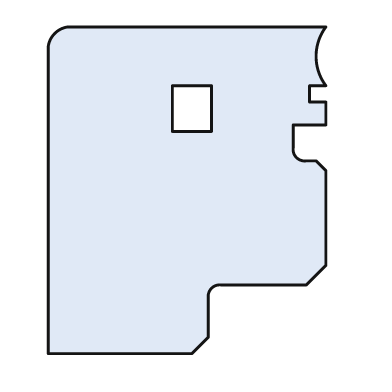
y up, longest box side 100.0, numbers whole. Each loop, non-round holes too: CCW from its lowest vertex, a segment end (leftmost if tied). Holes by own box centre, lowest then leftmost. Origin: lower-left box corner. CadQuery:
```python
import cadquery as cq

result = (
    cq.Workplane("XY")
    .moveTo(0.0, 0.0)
    .lineTo(44.0, 0.0)
    .lineTo(49.0, 5.0)
    .lineTo(49.0, 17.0)
    .threePointArc((50.0, 20.0), (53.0, 21.0))
    .lineTo(79.0, 21.0)
    .lineTo(85.0, 27.0)
    .lineTo(85.0, 56.0)
    .lineTo(82.0, 59.0)
    .lineTo(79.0, 59.0)
    .threePointArc((76.0, 60.0), (75.0, 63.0))
    .lineTo(75.0, 70.0)
    .lineTo(85.0, 70.0)
    .lineTo(85.0, 77.0)
    .lineTo(80.0, 77.0)
    .lineTo(80.0, 82.0)
    .lineTo(85.0, 82.0)
    .threePointArc((82.0, 91.0), (85.0, 100.0))
    .lineTo(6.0, 100.0)
    .threePointArc((2.0, 98.0), (0.0, 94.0))
    .close()
    .moveTo(38.0, 68.0)
    .lineTo(50.0, 68.0)
    .lineTo(50.0, 82.0)
    .lineTo(38.0, 82.0)
    .close()
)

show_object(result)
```